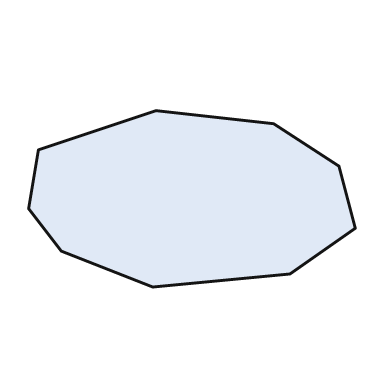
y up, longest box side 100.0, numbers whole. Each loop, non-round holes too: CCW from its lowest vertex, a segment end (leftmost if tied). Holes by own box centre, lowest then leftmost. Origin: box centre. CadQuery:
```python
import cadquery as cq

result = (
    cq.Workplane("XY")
    .moveTo(-12.0, -27.0)
    .lineTo(30.0, -23.0)
    .lineTo(50.0, -9.0)
    .lineTo(45.0, 10.0)
    .lineTo(25.0, 23.0)
    .lineTo(-11.0, 27.0)
    .lineTo(-47.0, 15.0)
    .lineTo(-50.0, -3.0)
    .lineTo(-40.0, -16.0)
    .close()
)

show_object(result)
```